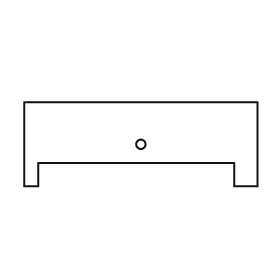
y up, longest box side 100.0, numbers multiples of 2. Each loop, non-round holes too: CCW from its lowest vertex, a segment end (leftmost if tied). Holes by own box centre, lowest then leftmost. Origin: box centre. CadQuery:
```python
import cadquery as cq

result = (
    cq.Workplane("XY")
    .moveTo(-50.0, -18.0)
    .lineTo(-44.0, -18.0)
    .lineTo(-44.0, -8.0)
    .lineTo(40.0, -8.0)
    .lineTo(40.0, -18.0)
    .lineTo(50.0, -18.0)
    .lineTo(50.0, 18.0)
    .lineTo(-50.0, 18.0)
    .close()
    .moveTo(0.0, 0.0)
    .circle(2.0)
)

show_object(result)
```